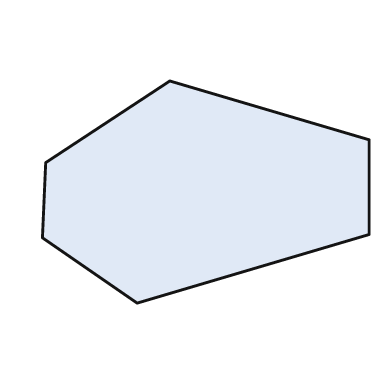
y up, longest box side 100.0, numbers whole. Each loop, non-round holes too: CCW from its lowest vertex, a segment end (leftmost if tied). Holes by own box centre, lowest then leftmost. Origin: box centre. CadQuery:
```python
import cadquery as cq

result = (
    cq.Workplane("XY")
    .moveTo(-21.0, -34.0)
    .lineTo(50.0, -13.0)
    .lineTo(50.0, 16.0)
    .lineTo(-11.0, 34.0)
    .lineTo(-49.0, 9.0)
    .lineTo(-50.0, -14.0)
    .close()
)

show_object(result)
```